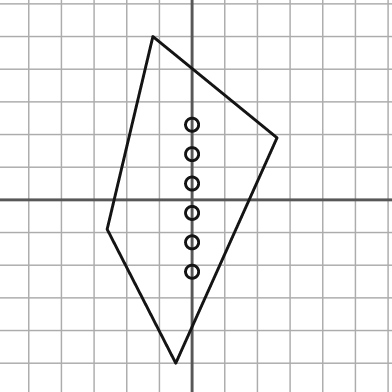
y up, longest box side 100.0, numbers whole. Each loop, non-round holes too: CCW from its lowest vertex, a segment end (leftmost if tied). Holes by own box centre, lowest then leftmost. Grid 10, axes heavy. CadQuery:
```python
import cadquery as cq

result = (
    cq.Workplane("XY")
    .moveTo(-5.0, -50.0)
    .lineTo(26.0, 19.0)
    .lineTo(-12.0, 50.0)
    .lineTo(-26.0, -9.0)
    .close()
    .moveTo(0.0, -22.0)
    .circle(2.0)
    .moveTo(0.0, -13.0)
    .circle(2.0)
    .moveTo(0.0, -4.0)
    .circle(2.0)
    .moveTo(0.0, 5.0)
    .circle(2.0)
    .moveTo(0.0, 14.0)
    .circle(2.0)
    .moveTo(0.0, 23.0)
    .circle(2.0)
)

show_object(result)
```